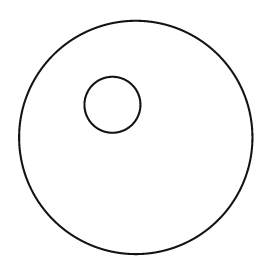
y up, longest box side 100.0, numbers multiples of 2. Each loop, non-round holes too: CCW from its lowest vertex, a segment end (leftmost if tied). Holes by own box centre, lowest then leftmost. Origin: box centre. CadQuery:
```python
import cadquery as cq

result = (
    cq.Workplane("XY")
    .moveTo(0.0, 0.0)
    .circle(50.0)
    .moveTo(-10.0, 14.0)
    .circle(12.0)
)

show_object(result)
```